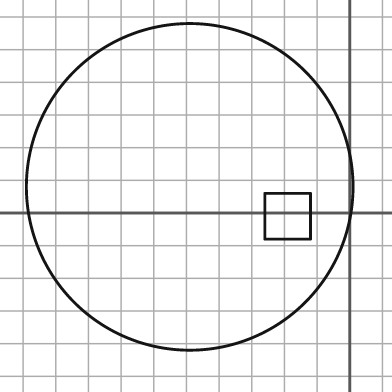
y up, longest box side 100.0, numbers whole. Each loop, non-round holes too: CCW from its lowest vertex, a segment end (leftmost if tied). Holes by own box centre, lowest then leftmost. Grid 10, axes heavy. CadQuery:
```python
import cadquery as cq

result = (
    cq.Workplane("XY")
    .moveTo(-49.0, 8.0)
    .circle(50.0)
    .moveTo(-26.0, -8.0)
    .lineTo(-12.0, -8.0)
    .lineTo(-12.0, 6.0)
    .lineTo(-26.0, 6.0)
    .close()
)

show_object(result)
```